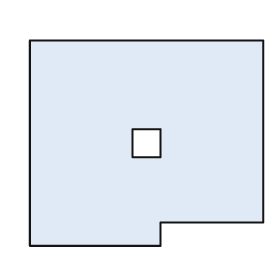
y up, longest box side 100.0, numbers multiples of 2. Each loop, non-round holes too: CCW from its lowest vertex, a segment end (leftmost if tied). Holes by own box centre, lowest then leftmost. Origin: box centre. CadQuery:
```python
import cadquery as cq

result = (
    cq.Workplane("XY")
    .moveTo(-50.0, -44.0)
    .lineTo(6.0, -44.0)
    .lineTo(6.0, -34.0)
    .lineTo(50.0, -34.0)
    .lineTo(50.0, 44.0)
    .lineTo(-50.0, 44.0)
    .close()
    .moveTo(-6.0, -6.0)
    .lineTo(6.0, -6.0)
    .lineTo(6.0, 6.0)
    .lineTo(-6.0, 6.0)
    .close()
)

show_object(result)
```